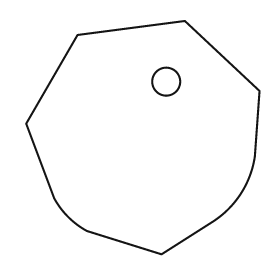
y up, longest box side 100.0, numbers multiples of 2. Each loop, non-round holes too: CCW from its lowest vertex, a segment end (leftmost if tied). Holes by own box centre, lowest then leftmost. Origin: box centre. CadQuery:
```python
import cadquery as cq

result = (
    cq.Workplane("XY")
    .moveTo(8.0, -50.0)
    .lineTo(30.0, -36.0)
    .threePointArc((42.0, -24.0), (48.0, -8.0))
    .lineTo(50.0, 20.0)
    .lineTo(18.0, 50.0)
    .lineTo(-28.0, 44.0)
    .lineTo(-50.0, 6.0)
    .lineTo(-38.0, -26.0)
    .threePointArc((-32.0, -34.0), (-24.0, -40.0))
    .close()
    .moveTo(10.0, 24.0)
    .circle(6.0)
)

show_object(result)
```